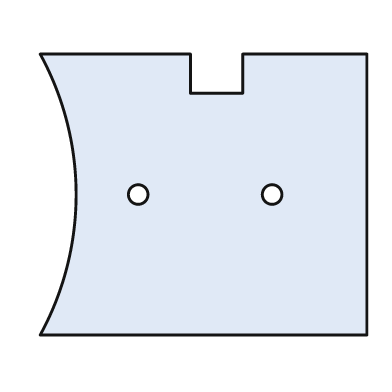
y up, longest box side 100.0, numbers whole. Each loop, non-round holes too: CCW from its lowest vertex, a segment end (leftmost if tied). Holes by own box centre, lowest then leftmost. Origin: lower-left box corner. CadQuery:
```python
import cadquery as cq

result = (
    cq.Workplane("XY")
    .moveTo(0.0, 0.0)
    .lineTo(100.0, 0.0)
    .lineTo(100.0, 86.0)
    .lineTo(62.0, 86.0)
    .lineTo(62.0, 74.0)
    .lineTo(46.0, 74.0)
    .lineTo(46.0, 86.0)
    .lineTo(0.0, 86.0)
    .threePointArc((11.0, 43.0), (0.0, 0.0))
    .close()
    .moveTo(30.0, 43.0)
    .circle(3.0)
    .moveTo(71.0, 43.0)
    .circle(3.0)
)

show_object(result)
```